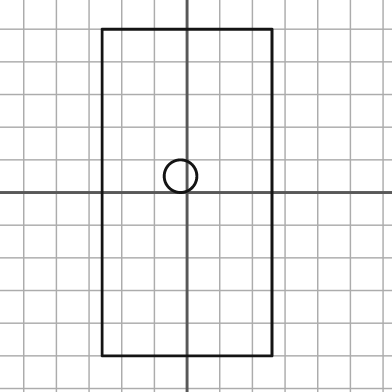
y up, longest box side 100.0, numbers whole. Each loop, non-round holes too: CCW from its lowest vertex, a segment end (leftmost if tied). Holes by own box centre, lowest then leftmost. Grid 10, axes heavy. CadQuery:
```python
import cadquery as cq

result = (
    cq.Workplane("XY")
    .moveTo(-26.0, -50.0)
    .lineTo(26.0, -50.0)
    .lineTo(26.0, 50.0)
    .lineTo(-26.0, 50.0)
    .close()
    .moveTo(-2.0, 5.0)
    .circle(5.0)
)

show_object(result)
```